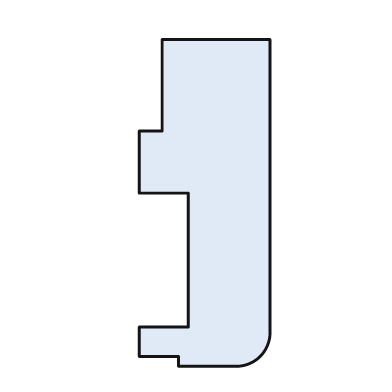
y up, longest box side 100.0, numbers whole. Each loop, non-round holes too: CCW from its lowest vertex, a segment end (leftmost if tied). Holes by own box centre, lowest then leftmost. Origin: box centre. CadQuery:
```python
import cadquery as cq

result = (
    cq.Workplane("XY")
    .moveTo(-8.0, -50.0)
    .lineTo(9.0, -50.0)
    .threePointArc((17.0, -47.0), (20.0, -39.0))
    .lineTo(20.0, 50.0)
    .lineTo(-13.0, 50.0)
    .lineTo(-13.0, 22.0)
    .lineTo(-20.0, 22.0)
    .lineTo(-20.0, 3.0)
    .lineTo(-5.0, 3.0)
    .lineTo(-5.0, -38.0)
    .lineTo(-20.0, -38.0)
    .lineTo(-20.0, -47.0)
    .lineTo(-8.0, -47.0)
    .close()
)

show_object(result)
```